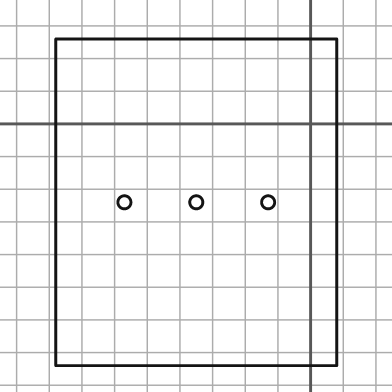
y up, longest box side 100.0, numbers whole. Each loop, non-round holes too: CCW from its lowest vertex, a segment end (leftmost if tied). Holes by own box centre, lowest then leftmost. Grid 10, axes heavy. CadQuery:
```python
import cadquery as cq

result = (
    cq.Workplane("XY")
    .moveTo(-78.0, -74.0)
    .lineTo(8.0, -74.0)
    .lineTo(8.0, 26.0)
    .lineTo(-78.0, 26.0)
    .close()
    .moveTo(-57.0, -24.0)
    .circle(2.0)
    .moveTo(-35.0, -24.0)
    .circle(2.0)
    .moveTo(-13.0, -24.0)
    .circle(2.0)
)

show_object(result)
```